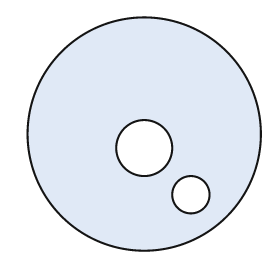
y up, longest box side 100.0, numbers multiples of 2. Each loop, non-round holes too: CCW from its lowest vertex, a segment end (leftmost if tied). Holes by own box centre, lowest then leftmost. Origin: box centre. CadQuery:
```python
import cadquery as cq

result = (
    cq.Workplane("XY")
    .moveTo(0.0, 0.0)
    .circle(50.0)
    .moveTo(20.0, -26.0)
    .circle(8.0)
    .moveTo(0.0, -6.0)
    .circle(12.0)
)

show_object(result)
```